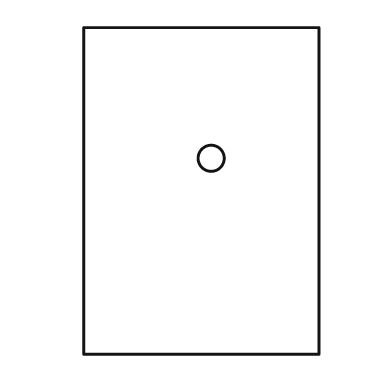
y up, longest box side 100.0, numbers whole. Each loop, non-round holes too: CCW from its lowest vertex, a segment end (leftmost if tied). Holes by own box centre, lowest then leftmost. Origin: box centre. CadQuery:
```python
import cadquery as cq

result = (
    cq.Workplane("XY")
    .moveTo(-36.0, -50.0)
    .lineTo(36.0, -50.0)
    .lineTo(36.0, 50.0)
    .lineTo(-36.0, 50.0)
    .close()
    .moveTo(3.0, 10.0)
    .circle(4.0)
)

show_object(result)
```